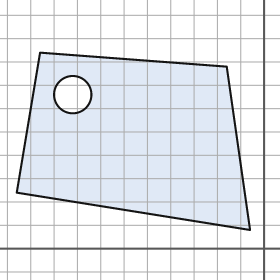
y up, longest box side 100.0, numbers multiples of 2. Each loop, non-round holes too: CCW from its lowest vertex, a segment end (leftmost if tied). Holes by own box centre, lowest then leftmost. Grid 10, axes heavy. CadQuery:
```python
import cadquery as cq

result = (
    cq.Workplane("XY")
    .moveTo(-6.0, 8.0)
    .lineTo(-16.0, 78.0)
    .lineTo(-96.0, 84.0)
    .lineTo(-106.0, 24.0)
    .close()
    .moveTo(-82.0, 66.0)
    .circle(8.0)
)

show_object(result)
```